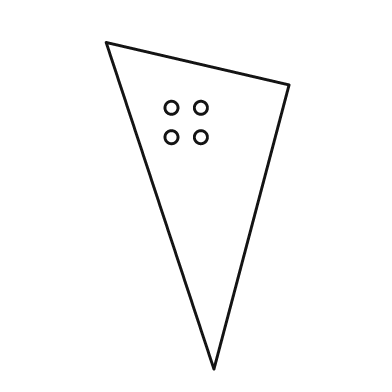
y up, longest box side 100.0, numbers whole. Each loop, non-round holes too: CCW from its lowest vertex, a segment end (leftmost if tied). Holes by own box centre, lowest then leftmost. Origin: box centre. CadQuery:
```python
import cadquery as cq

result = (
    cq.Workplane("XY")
    .moveTo(5.0, -50.0)
    .lineTo(28.0, 37.0)
    .lineTo(-28.0, 50.0)
    .close()
    .moveTo(-8.0, 21.0)
    .circle(2.0)
    .moveTo(1.0, 21.0)
    .circle(2.0)
    .moveTo(-8.0, 30.0)
    .circle(2.0)
    .moveTo(1.0, 30.0)
    .circle(2.0)
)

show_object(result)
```